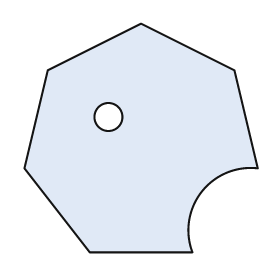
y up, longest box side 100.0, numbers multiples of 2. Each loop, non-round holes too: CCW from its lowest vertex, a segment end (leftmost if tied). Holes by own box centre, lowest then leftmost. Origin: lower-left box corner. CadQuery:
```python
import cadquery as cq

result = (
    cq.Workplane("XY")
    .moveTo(28.0, 0.0)
    .lineTo(72.0, 0.0)
    .threePointArc((76.0, 26.0), (100.0, 36.0))
    .lineTo(90.0, 78.0)
    .lineTo(50.0, 98.0)
    .lineTo(10.0, 78.0)
    .lineTo(0.0, 36.0)
    .close()
    .moveTo(36.0, 58.0)
    .circle(6.0)
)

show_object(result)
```